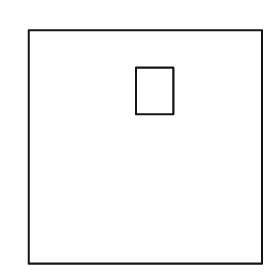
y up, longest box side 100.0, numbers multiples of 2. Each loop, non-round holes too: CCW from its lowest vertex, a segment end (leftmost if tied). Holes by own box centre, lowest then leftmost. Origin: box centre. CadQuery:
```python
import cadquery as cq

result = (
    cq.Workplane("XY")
    .moveTo(-50.0, -50.0)
    .lineTo(50.0, -50.0)
    .lineTo(50.0, 50.0)
    .lineTo(-50.0, 50.0)
    .close()
    .moveTo(-4.0, 14.0)
    .lineTo(12.0, 14.0)
    .lineTo(12.0, 34.0)
    .lineTo(-4.0, 34.0)
    .close()
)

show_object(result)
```